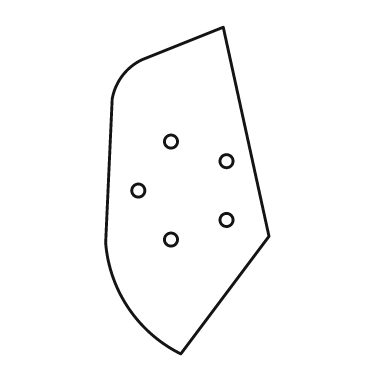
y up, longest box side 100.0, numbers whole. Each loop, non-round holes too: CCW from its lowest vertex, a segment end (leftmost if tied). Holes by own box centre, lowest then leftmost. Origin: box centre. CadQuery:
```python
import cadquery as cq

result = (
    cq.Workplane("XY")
    .moveTo(-2.0, -50.0)
    .lineTo(25.0, -14.0)
    .lineTo(11.0, 50.0)
    .lineTo(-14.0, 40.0)
    .threePointArc((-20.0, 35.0), (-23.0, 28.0))
    .lineTo(-25.0, -16.0)
    .threePointArc((-18.0, -36.0), (-2.0, -50.0))
    .close()
    .moveTo(-5.0, -15.0)
    .circle(2.0)
    .moveTo(12.0, -9.0)
    .circle(2.0)
    .moveTo(-15.0, 0.0)
    .circle(2.0)
    .moveTo(12.0, 9.0)
    .circle(2.0)
    .moveTo(-5.0, 15.0)
    .circle(2.0)
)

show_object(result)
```